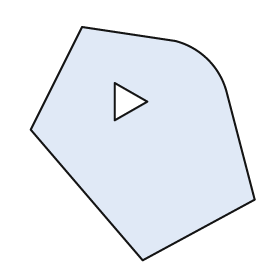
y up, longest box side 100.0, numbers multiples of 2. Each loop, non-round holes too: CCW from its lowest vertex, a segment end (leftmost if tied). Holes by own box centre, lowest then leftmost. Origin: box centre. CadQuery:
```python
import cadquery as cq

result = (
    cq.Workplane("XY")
    .moveTo(0.0, -50.0)
    .lineTo(48.0, -24.0)
    .lineTo(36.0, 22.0)
    .threePointArc((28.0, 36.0), (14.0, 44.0))
    .lineTo(-26.0, 50.0)
    .lineTo(-48.0, 6.0)
    .close()
    .moveTo(-12.0, 10.0)
    .lineTo(2.0, 18.0)
    .lineTo(-12.0, 26.0)
    .close()
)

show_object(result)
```